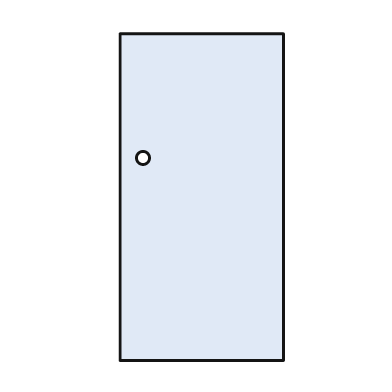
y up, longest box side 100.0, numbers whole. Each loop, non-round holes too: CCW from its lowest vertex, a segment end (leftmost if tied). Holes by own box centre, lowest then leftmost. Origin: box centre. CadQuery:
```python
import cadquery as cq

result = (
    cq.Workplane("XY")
    .moveTo(-25.0, -50.0)
    .lineTo(25.0, -50.0)
    .lineTo(25.0, 50.0)
    .lineTo(-25.0, 50.0)
    .close()
    .moveTo(-18.0, 12.0)
    .circle(2.0)
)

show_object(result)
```